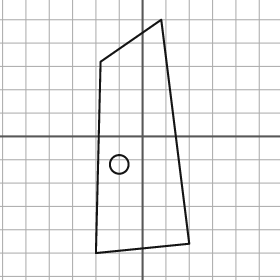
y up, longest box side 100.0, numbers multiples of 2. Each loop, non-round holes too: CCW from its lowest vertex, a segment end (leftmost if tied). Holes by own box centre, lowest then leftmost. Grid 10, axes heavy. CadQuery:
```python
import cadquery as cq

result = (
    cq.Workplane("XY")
    .moveTo(-20.0, -50.0)
    .lineTo(20.0, -46.0)
    .lineTo(8.0, 50.0)
    .lineTo(-18.0, 32.0)
    .close()
    .moveTo(-10.0, -12.0)
    .circle(4.0)
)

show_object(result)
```